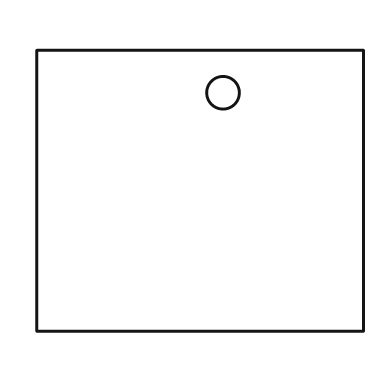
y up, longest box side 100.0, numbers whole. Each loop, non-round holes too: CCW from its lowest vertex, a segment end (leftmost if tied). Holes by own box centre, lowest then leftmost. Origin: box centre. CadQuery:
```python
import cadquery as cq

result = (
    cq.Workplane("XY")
    .moveTo(-50.0, -43.0)
    .lineTo(50.0, -43.0)
    .lineTo(50.0, 43.0)
    .lineTo(-50.0, 43.0)
    .close()
    .moveTo(7.0, 30.0)
    .circle(5.0)
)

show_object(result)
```